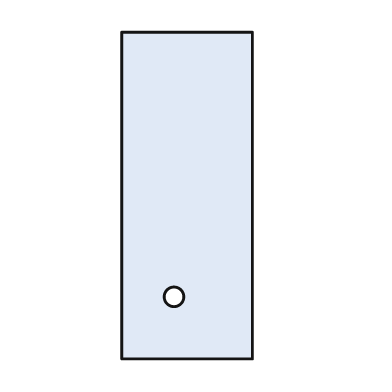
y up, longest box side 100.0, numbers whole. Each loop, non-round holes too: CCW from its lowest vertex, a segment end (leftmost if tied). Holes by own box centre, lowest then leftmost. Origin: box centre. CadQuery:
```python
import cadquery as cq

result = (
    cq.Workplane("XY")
    .moveTo(-20.0, -50.0)
    .lineTo(20.0, -50.0)
    .lineTo(20.0, 50.0)
    .lineTo(-20.0, 50.0)
    .close()
    .moveTo(-4.0, -31.0)
    .circle(3.0)
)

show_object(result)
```